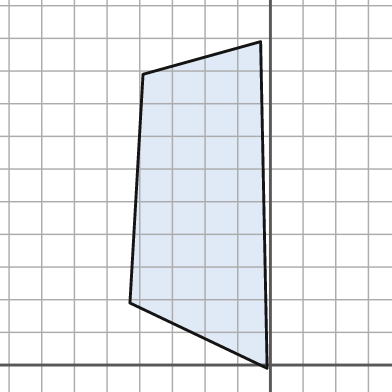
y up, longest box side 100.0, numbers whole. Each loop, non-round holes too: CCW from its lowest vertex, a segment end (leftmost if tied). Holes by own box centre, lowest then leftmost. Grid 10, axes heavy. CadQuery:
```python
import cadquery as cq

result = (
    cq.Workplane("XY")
    .moveTo(-1.0, -1.0)
    .lineTo(-3.0, 99.0)
    .lineTo(-39.0, 89.0)
    .lineTo(-43.0, 19.0)
    .close()
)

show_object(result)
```